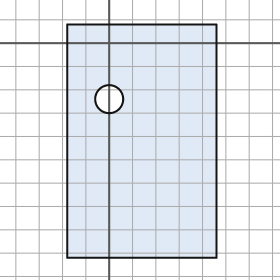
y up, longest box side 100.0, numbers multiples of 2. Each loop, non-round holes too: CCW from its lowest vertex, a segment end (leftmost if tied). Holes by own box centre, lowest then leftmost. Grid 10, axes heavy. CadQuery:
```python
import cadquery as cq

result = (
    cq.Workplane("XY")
    .moveTo(-18.0, -92.0)
    .lineTo(46.0, -92.0)
    .lineTo(46.0, 8.0)
    .lineTo(-18.0, 8.0)
    .close()
    .moveTo(0.0, -24.0)
    .circle(6.0)
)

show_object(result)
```